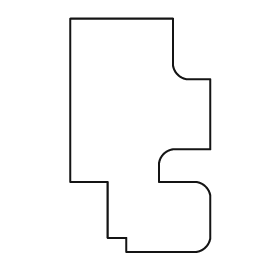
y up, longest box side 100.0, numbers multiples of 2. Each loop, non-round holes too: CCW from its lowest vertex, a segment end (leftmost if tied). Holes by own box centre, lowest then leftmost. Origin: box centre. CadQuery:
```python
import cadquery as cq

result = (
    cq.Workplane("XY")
    .moveTo(-6.0, -50.0)
    .lineTo(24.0, -50.0)
    .threePointArc((28.0, -48.0), (30.0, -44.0))
    .lineTo(30.0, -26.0)
    .threePointArc((28.0, -22.0), (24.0, -20.0))
    .lineTo(8.0, -20.0)
    .lineTo(8.0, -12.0)
    .threePointArc((10.0, -8.0), (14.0, -6.0))
    .lineTo(30.0, -6.0)
    .lineTo(30.0, 24.0)
    .lineTo(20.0, 24.0)
    .threePointArc((16.0, 26.0), (14.0, 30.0))
    .lineTo(14.0, 50.0)
    .lineTo(-30.0, 50.0)
    .lineTo(-30.0, -20.0)
    .lineTo(-14.0, -20.0)
    .lineTo(-14.0, -44.0)
    .lineTo(-6.0, -44.0)
    .close()
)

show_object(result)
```